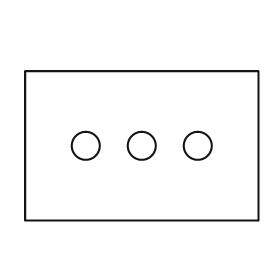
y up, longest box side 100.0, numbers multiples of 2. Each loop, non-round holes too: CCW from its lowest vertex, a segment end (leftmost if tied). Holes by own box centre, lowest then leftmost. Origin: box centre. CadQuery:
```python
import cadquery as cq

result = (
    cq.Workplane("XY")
    .moveTo(-50.0, -32.0)
    .lineTo(50.0, -32.0)
    .lineTo(50.0, 32.0)
    .lineTo(-50.0, 32.0)
    .close()
    .moveTo(-24.0, 0.0)
    .circle(6.0)
    .moveTo(0.0, 0.0)
    .circle(6.0)
    .moveTo(24.0, 0.0)
    .circle(6.0)
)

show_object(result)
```